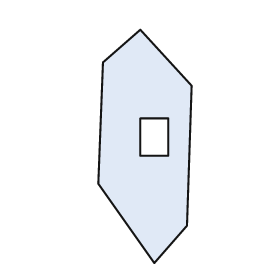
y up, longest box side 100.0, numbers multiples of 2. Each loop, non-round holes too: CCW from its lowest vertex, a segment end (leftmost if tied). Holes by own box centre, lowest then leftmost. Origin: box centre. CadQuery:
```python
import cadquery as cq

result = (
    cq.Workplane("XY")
    .moveTo(4.0, -50.0)
    .lineTo(18.0, -34.0)
    .lineTo(20.0, 26.0)
    .lineTo(-2.0, 50.0)
    .lineTo(-18.0, 36.0)
    .lineTo(-20.0, -16.0)
    .close()
    .moveTo(-2.0, -4.0)
    .lineTo(10.0, -4.0)
    .lineTo(10.0, 12.0)
    .lineTo(-2.0, 12.0)
    .close()
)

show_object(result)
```